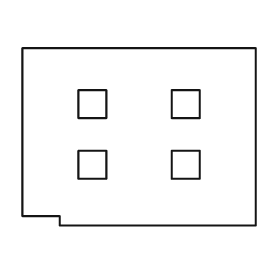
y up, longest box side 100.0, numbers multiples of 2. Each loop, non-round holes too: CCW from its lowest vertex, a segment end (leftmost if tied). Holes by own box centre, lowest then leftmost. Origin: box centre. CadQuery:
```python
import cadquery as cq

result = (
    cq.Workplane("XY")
    .moveTo(-34.0, -38.0)
    .lineTo(50.0, -38.0)
    .lineTo(50.0, 38.0)
    .lineTo(-50.0, 38.0)
    .lineTo(-50.0, -34.0)
    .lineTo(-34.0, -34.0)
    .close()
    .moveTo(-26.0, -18.0)
    .lineTo(-14.0, -18.0)
    .lineTo(-14.0, -6.0)
    .lineTo(-26.0, -6.0)
    .close()
    .moveTo(14.0, -18.0)
    .lineTo(26.0, -18.0)
    .lineTo(26.0, -6.0)
    .lineTo(14.0, -6.0)
    .close()
    .moveTo(-26.0, 8.0)
    .lineTo(-14.0, 8.0)
    .lineTo(-14.0, 20.0)
    .lineTo(-26.0, 20.0)
    .close()
    .moveTo(14.0, 8.0)
    .lineTo(26.0, 8.0)
    .lineTo(26.0, 20.0)
    .lineTo(14.0, 20.0)
    .close()
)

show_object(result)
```